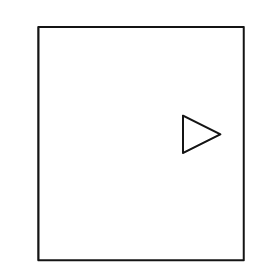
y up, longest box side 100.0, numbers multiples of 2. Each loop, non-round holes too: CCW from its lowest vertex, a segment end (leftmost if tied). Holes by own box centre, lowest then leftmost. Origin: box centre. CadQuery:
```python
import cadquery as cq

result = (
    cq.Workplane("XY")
    .moveTo(-44.0, -50.0)
    .lineTo(44.0, -50.0)
    .lineTo(44.0, 50.0)
    .lineTo(-44.0, 50.0)
    .close()
    .moveTo(18.0, -4.0)
    .lineTo(34.0, 4.0)
    .lineTo(18.0, 12.0)
    .close()
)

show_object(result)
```